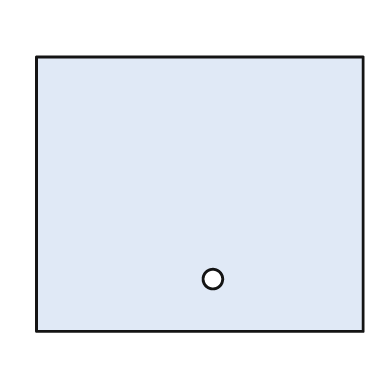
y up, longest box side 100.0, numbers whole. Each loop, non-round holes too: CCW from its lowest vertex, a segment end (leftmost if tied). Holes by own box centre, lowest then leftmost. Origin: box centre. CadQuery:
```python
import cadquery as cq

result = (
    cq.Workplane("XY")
    .moveTo(-50.0, -42.0)
    .lineTo(50.0, -42.0)
    .lineTo(50.0, 42.0)
    .lineTo(-50.0, 42.0)
    .close()
    .moveTo(4.0, -26.0)
    .circle(3.0)
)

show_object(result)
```